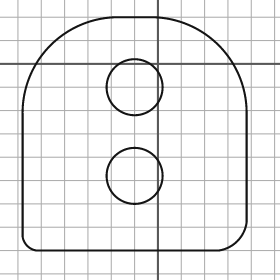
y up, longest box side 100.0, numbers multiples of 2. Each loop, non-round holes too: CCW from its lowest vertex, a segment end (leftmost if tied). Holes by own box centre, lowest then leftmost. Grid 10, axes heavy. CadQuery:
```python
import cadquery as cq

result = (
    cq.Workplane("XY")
    .moveTo(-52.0, -80.0)
    .lineTo(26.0, -80.0)
    .threePointArc((34.0, -76.0), (38.0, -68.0))
    .lineTo(38.0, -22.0)
    .threePointArc((26.0, 8.0), (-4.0, 20.0))
    .lineTo(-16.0, 20.0)
    .threePointArc((-46.0, 8.0), (-58.0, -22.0))
    .lineTo(-58.0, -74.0)
    .threePointArc((-56.0, -78.0), (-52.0, -80.0))
    .close()
    .moveTo(-10.0, -48.0)
    .circle(12.0)
    .moveTo(-10.0, -10.0)
    .circle(12.0)
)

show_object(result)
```